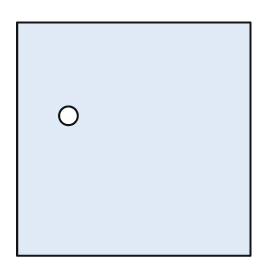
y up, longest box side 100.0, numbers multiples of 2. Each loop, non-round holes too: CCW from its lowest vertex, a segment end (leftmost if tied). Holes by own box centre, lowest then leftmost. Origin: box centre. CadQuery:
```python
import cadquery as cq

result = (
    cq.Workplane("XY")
    .moveTo(-50.0, -50.0)
    .lineTo(50.0, -50.0)
    .lineTo(50.0, 50.0)
    .lineTo(-50.0, 50.0)
    .close()
    .moveTo(-28.0, 10.0)
    .circle(4.0)
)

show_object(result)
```